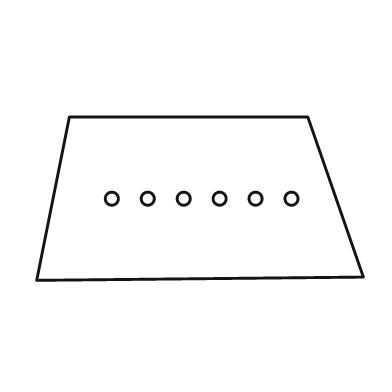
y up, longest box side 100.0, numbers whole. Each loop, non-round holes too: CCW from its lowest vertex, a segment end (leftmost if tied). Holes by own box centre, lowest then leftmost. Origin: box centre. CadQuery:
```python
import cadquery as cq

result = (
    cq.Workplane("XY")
    .moveTo(-50.0, -25.0)
    .lineTo(50.0, -24.0)
    .lineTo(33.0, 25.0)
    .lineTo(-40.0, 25.0)
    .close()
    .moveTo(-27.0, 0.0)
    .circle(2.0)
    .moveTo(-16.0, 0.0)
    .circle(2.0)
    .moveTo(-5.0, 0.0)
    .circle(2.0)
    .moveTo(6.0, 0.0)
    .circle(2.0)
    .moveTo(17.0, 0.0)
    .circle(2.0)
    .moveTo(28.0, 0.0)
    .circle(2.0)
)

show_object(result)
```